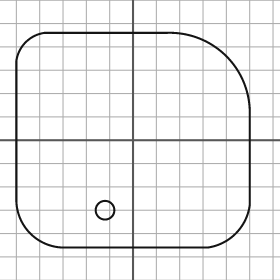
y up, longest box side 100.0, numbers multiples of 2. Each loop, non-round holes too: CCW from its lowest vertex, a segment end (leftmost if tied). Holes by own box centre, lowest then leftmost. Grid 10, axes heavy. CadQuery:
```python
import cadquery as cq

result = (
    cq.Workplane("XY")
    .moveTo(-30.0, -46.0)
    .lineTo(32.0, -46.0)
    .threePointArc((44.0, -40.0), (50.0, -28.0))
    .lineTo(50.0, 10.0)
    .threePointArc((40.0, 36.0), (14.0, 46.0))
    .lineTo(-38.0, 46.0)
    .threePointArc((-46.0, 42.0), (-50.0, 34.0))
    .lineTo(-50.0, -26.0)
    .threePointArc((-44.0, -40.0), (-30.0, -46.0))
    .close()
    .moveTo(-12.0, -30.0)
    .circle(4.0)
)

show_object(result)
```